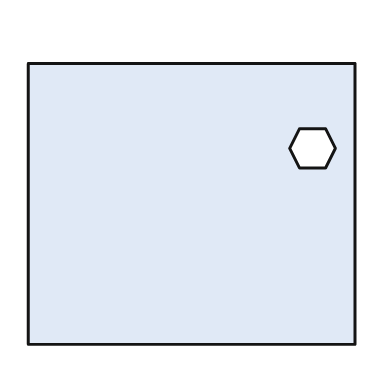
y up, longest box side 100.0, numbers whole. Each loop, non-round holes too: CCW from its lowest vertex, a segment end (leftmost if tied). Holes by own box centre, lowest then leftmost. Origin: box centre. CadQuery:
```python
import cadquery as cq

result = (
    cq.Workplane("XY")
    .moveTo(-50.0, -43.0)
    .lineTo(50.0, -43.0)
    .lineTo(50.0, 43.0)
    .lineTo(-50.0, 43.0)
    .close()
    .moveTo(33.0, 11.0)
    .lineTo(41.0, 11.0)
    .lineTo(44.0, 17.0)
    .lineTo(41.0, 23.0)
    .lineTo(33.0, 23.0)
    .lineTo(30.0, 17.0)
    .close()
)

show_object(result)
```